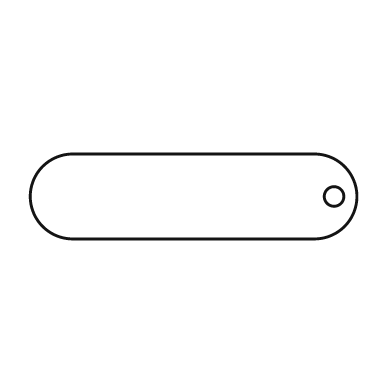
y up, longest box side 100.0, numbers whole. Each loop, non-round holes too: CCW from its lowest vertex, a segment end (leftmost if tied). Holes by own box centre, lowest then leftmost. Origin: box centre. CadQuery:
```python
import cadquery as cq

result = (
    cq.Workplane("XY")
    .moveTo(-37.0, -13.0)
    .lineTo(37.0, -13.0)
    .threePointArc((50.0, 0.0), (37.0, 13.0))
    .lineTo(-37.0, 13.0)
    .threePointArc((-50.0, 0.0), (-37.0, -13.0))
    .close()
    .moveTo(43.0, 0.0)
    .circle(3.0)
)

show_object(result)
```